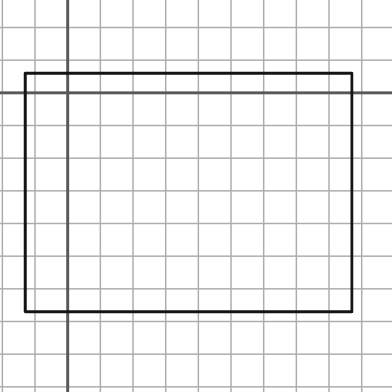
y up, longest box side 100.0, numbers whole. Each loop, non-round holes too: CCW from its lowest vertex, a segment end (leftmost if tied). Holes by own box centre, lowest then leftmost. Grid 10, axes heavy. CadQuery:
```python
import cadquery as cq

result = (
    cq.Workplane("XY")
    .moveTo(-13.0, -67.0)
    .lineTo(87.0, -67.0)
    .lineTo(87.0, 6.0)
    .lineTo(-13.0, 6.0)
    .close()
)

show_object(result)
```